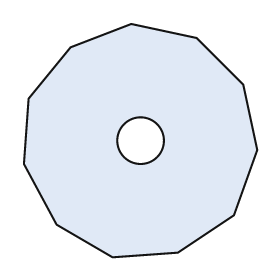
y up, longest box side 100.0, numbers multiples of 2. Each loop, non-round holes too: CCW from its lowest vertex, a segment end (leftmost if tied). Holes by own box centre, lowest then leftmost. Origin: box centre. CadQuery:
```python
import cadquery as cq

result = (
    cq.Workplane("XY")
    .moveTo(-12.0, -50.0)
    .lineTo(16.0, -48.0)
    .lineTo(40.0, -32.0)
    .lineTo(50.0, -4.0)
    .lineTo(44.0, 24.0)
    .lineTo(24.0, 44.0)
    .lineTo(-4.0, 50.0)
    .lineTo(-30.0, 40.0)
    .lineTo(-48.0, 18.0)
    .lineTo(-50.0, -10.0)
    .lineTo(-36.0, -36.0)
    .close()
    .moveTo(0.0, 0.0)
    .circle(10.0)
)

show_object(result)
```